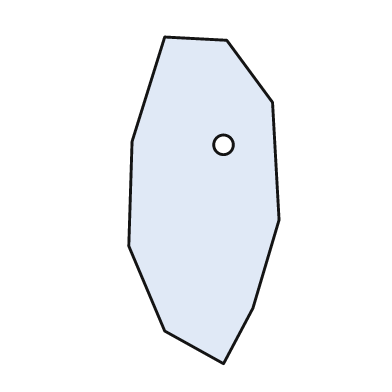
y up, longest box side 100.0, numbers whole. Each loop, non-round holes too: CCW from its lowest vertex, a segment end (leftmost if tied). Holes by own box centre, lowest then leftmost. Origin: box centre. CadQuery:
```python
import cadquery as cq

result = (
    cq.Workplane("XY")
    .moveTo(6.0, -50.0)
    .lineTo(15.0, -33.0)
    .lineTo(23.0, -6.0)
    .lineTo(21.0, 30.0)
    .lineTo(7.0, 49.0)
    .lineTo(-12.0, 50.0)
    .lineTo(-22.0, 18.0)
    .lineTo(-23.0, -14.0)
    .lineTo(-12.0, -40.0)
    .close()
    .moveTo(6.0, 17.0)
    .circle(3.0)
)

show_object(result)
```